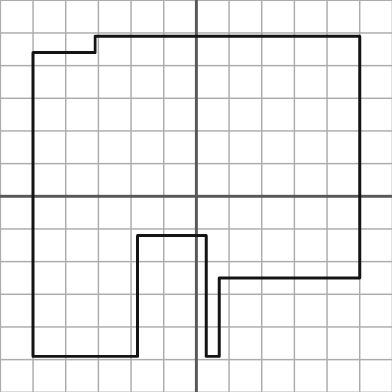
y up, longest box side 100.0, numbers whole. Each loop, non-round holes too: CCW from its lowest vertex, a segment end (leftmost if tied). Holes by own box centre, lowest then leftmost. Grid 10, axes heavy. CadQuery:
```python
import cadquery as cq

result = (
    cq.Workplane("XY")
    .moveTo(-50.0, -49.0)
    .lineTo(-18.0, -49.0)
    .lineTo(-18.0, -12.0)
    .lineTo(3.0, -12.0)
    .lineTo(3.0, -49.0)
    .lineTo(7.0, -49.0)
    .lineTo(7.0, -25.0)
    .lineTo(50.0, -25.0)
    .lineTo(50.0, 49.0)
    .lineTo(-31.0, 49.0)
    .lineTo(-31.0, 44.0)
    .lineTo(-50.0, 44.0)
    .close()
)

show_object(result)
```